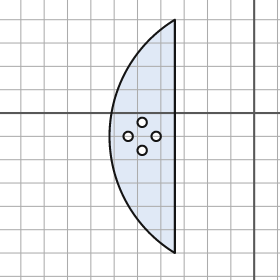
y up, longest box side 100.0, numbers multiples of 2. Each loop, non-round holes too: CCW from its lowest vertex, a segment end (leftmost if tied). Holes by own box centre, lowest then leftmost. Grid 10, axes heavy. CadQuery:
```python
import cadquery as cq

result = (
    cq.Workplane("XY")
    .moveTo(-34.0, -60.0)
    .lineTo(-34.0, 40.0)
    .threePointArc((-62.0, -10.0), (-34.0, -60.0))
    .close()
    .moveTo(-48.0, -16.0)
    .circle(2.0)
    .moveTo(-54.0, -10.0)
    .circle(2.0)
    .moveTo(-42.0, -10.0)
    .circle(2.0)
    .moveTo(-48.0, -4.0)
    .circle(2.0)
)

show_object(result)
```